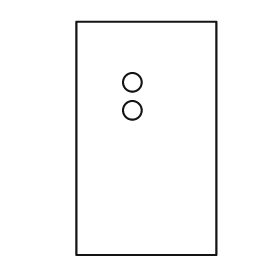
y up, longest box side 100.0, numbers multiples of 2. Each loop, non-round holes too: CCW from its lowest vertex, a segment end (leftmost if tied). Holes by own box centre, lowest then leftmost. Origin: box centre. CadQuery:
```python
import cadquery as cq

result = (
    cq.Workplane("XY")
    .moveTo(-30.0, -50.0)
    .lineTo(30.0, -50.0)
    .lineTo(30.0, 50.0)
    .lineTo(-30.0, 50.0)
    .close()
    .moveTo(-6.0, 12.0)
    .circle(4.0)
    .moveTo(-6.0, 24.0)
    .circle(4.0)
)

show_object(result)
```